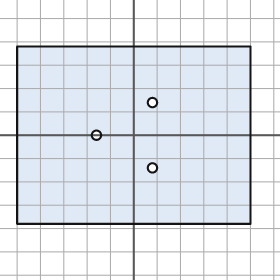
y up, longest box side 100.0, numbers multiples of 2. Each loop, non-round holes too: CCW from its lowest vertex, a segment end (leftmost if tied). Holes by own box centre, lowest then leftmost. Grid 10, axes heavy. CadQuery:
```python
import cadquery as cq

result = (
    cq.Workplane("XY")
    .moveTo(-50.0, -38.0)
    .lineTo(50.0, -38.0)
    .lineTo(50.0, 38.0)
    .lineTo(-50.0, 38.0)
    .close()
    .moveTo(8.0, -14.0)
    .circle(2.0)
    .moveTo(-16.0, 0.0)
    .circle(2.0)
    .moveTo(8.0, 14.0)
    .circle(2.0)
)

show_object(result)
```